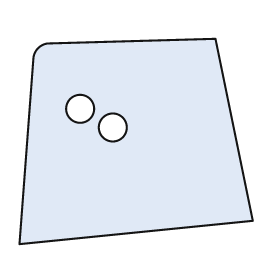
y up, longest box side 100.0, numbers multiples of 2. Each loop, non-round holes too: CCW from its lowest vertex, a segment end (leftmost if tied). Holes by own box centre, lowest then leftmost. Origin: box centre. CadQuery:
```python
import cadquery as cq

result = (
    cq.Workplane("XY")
    .moveTo(-50.0, -44.0)
    .lineTo(50.0, -34.0)
    .lineTo(34.0, 44.0)
    .lineTo(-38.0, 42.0)
    .threePointArc((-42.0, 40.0), (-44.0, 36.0))
    .close()
    .moveTo(-10.0, 6.0)
    .circle(6.0)
    .moveTo(-24.0, 14.0)
    .circle(6.0)
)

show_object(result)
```